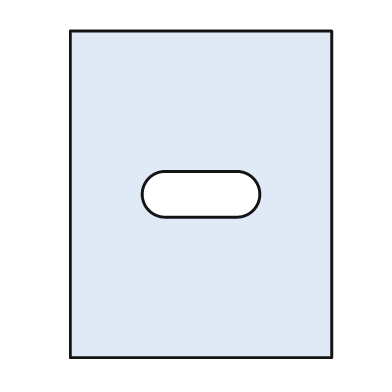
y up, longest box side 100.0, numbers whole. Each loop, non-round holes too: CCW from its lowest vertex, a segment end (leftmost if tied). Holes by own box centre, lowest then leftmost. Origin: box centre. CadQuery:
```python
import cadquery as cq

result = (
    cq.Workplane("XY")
    .moveTo(-40.0, -50.0)
    .lineTo(40.0, -50.0)
    .lineTo(40.0, 50.0)
    .lineTo(-40.0, 50.0)
    .close()
    .moveTo(-11.0, -7.0)
    .lineTo(11.0, -7.0)
    .threePointArc((18.0, 0.0), (11.0, 7.0))
    .lineTo(-11.0, 7.0)
    .threePointArc((-18.0, 0.0), (-11.0, -7.0))
    .close()
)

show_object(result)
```